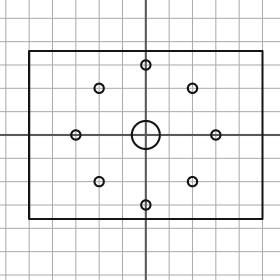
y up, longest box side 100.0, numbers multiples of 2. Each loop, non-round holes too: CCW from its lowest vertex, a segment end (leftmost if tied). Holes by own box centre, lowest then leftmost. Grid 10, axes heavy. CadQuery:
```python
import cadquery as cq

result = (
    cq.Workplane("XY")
    .moveTo(-50.0, -36.0)
    .lineTo(50.0, -36.0)
    .lineTo(50.0, 36.0)
    .lineTo(-50.0, 36.0)
    .close()
    .moveTo(0.0, -30.0)
    .circle(2.0)
    .moveTo(-20.0, -20.0)
    .circle(2.0)
    .moveTo(20.0, -20.0)
    .circle(2.0)
    .moveTo(-30.0, 0.0)
    .circle(2.0)
    .moveTo(0.0, 0.0)
    .circle(6.0)
    .moveTo(30.0, 0.0)
    .circle(2.0)
    .moveTo(-20.0, 20.0)
    .circle(2.0)
    .moveTo(20.0, 20.0)
    .circle(2.0)
    .moveTo(0.0, 30.0)
    .circle(2.0)
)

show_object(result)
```